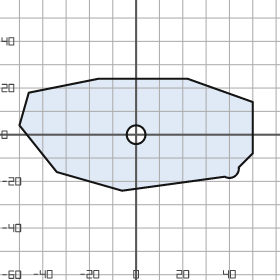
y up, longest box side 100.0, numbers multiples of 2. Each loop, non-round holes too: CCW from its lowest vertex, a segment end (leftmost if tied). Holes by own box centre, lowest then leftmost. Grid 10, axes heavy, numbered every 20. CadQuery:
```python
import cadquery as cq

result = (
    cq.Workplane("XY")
    .moveTo(-6.0, -24.0)
    .lineTo(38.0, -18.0)
    .threePointArc((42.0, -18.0), (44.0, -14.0))
    .lineTo(50.0, -8.0)
    .lineTo(50.0, 14.0)
    .lineTo(22.0, 24.0)
    .lineTo(-16.0, 24.0)
    .lineTo(-46.0, 18.0)
    .lineTo(-50.0, 4.0)
    .lineTo(-34.0, -16.0)
    .close()
    .moveTo(0.0, 0.0)
    .circle(4.0)
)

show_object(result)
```